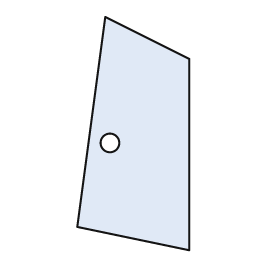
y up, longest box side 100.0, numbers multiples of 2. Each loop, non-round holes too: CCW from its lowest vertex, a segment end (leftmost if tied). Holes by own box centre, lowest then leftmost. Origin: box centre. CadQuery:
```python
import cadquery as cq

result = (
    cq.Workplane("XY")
    .moveTo(24.0, -50.0)
    .lineTo(24.0, 32.0)
    .lineTo(-12.0, 50.0)
    .lineTo(-24.0, -40.0)
    .close()
    .moveTo(-10.0, -4.0)
    .circle(4.0)
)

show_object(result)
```